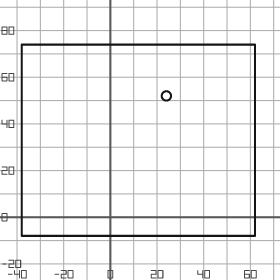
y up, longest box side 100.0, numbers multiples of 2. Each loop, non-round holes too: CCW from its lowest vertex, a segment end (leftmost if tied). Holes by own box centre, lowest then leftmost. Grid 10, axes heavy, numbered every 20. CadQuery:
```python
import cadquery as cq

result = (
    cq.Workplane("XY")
    .moveTo(-38.0, -8.0)
    .lineTo(62.0, -8.0)
    .lineTo(62.0, 74.0)
    .lineTo(-38.0, 74.0)
    .close()
    .moveTo(24.0, 52.0)
    .circle(2.0)
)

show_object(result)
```